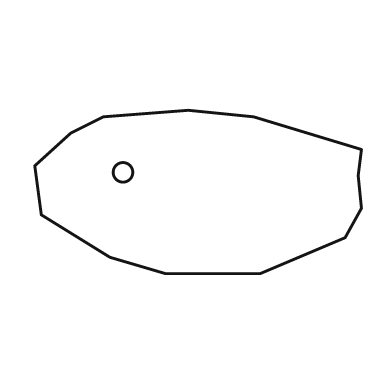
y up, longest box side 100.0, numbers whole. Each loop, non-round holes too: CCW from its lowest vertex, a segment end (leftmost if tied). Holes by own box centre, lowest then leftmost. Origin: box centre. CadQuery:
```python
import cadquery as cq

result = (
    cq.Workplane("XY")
    .moveTo(-10.0, -25.0)
    .lineTo(19.0, -25.0)
    .lineTo(45.0, -14.0)
    .lineTo(50.0, -5.0)
    .lineTo(49.0, 5.0)
    .lineTo(50.0, 13.0)
    .lineTo(17.0, 23.0)
    .lineTo(-3.0, 25.0)
    .lineTo(-29.0, 23.0)
    .lineTo(-39.0, 18.0)
    .lineTo(-50.0, 8.0)
    .lineTo(-48.0, -7.0)
    .lineTo(-27.0, -20.0)
    .close()
    .moveTo(-23.0, 6.0)
    .circle(3.0)
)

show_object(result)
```